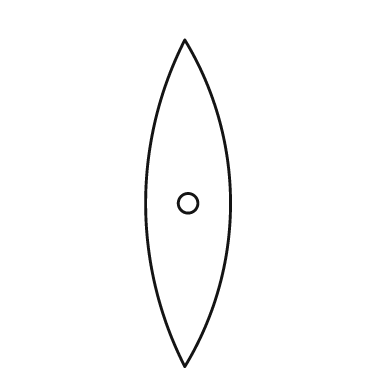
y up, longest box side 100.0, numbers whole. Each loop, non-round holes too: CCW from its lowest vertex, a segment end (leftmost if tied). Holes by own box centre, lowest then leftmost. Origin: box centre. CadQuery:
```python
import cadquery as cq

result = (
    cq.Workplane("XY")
    .moveTo(-1.0, -50.0)
    .threePointArc((13.0, 0.0), (-1.0, 50.0))
    .threePointArc((-13.0, 0.0), (-1.0, -50.0))
    .close()
    .moveTo(0.0, 0.0)
    .circle(3.0)
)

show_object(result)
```